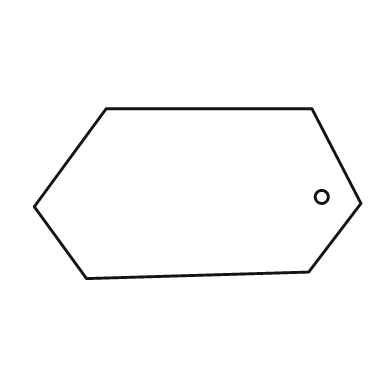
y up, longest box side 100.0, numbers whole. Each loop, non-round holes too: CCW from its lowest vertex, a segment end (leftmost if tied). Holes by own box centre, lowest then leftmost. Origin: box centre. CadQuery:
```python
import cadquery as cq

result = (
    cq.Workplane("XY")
    .moveTo(-34.0, -26.0)
    .lineTo(34.0, -24.0)
    .lineTo(50.0, -3.0)
    .lineTo(35.0, 26.0)
    .lineTo(-28.0, 26.0)
    .lineTo(-50.0, -4.0)
    .close()
    .moveTo(38.0, -1.0)
    .circle(2.0)
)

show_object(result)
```